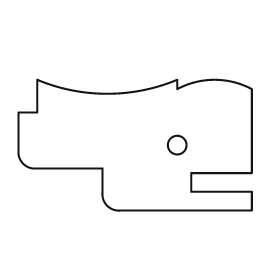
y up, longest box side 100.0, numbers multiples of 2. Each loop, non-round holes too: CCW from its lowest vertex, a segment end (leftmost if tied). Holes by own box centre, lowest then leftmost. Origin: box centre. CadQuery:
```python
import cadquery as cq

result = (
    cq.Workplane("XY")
    .moveTo(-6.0, -28.0)
    .lineTo(50.0, -28.0)
    .lineTo(50.0, -20.0)
    .lineTo(24.0, -20.0)
    .lineTo(24.0, -12.0)
    .lineTo(50.0, -12.0)
    .lineTo(50.0, 24.0)
    .threePointArc((34.0, 28.0), (18.0, 24.0))
    .lineTo(18.0, 28.0)
    .threePointArc((-12.0, 22.0), (-42.0, 28.0))
    .lineTo(-42.0, 14.0)
    .lineTo(-50.0, 14.0)
    .lineTo(-50.0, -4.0)
    .threePointArc((-48.0, -8.0), (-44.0, -10.0))
    .lineTo(-14.0, -10.0)
    .lineTo(-14.0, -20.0)
    .threePointArc((-12.0, -26.0), (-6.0, -28.0))
    .close()
    .moveTo(18.0, 0.0)
    .circle(4.0)
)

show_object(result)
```